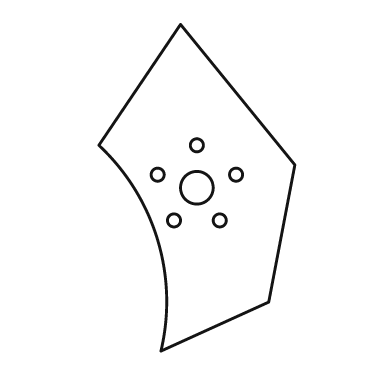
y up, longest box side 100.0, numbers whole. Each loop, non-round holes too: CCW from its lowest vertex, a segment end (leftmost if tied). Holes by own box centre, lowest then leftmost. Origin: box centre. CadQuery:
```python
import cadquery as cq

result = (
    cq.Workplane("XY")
    .moveTo(-11.0, -50.0)
    .lineTo(22.0, -35.0)
    .lineTo(30.0, 7.0)
    .lineTo(-5.0, 50.0)
    .lineTo(-30.0, 13.0)
    .threePointArc((-12.0, -16.0), (-11.0, -50.0))
    .close()
    .moveTo(-7.0, -10.0)
    .circle(2.0)
    .moveTo(7.0, -10.0)
    .circle(2.0)
    .moveTo(0.0, 0.0)
    .circle(5.0)
    .moveTo(-12.0, 4.0)
    .circle(2.0)
    .moveTo(12.0, 4.0)
    .circle(2.0)
    .moveTo(0.0, 13.0)
    .circle(2.0)
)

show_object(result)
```